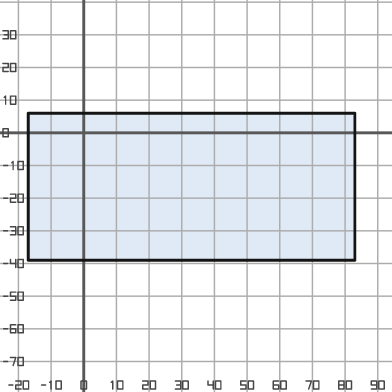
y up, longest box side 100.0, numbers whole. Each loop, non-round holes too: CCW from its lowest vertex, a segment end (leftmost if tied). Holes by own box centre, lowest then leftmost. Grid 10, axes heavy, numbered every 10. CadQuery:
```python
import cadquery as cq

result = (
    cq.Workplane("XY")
    .moveTo(-17.0, -39.0)
    .lineTo(83.0, -39.0)
    .lineTo(83.0, 6.0)
    .lineTo(-17.0, 6.0)
    .close()
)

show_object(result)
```